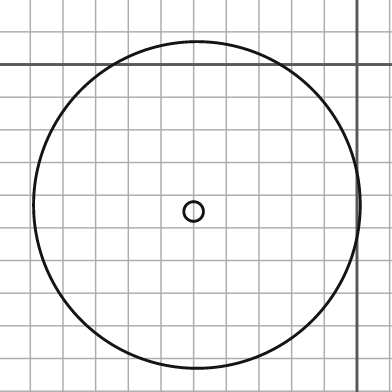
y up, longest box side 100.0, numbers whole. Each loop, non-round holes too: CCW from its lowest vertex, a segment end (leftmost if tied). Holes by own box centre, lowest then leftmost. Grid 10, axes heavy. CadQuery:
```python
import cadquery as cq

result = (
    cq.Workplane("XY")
    .moveTo(-49.0, -43.0)
    .circle(50.0)
    .moveTo(-50.0, -45.0)
    .circle(3.0)
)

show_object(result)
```